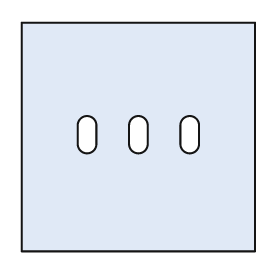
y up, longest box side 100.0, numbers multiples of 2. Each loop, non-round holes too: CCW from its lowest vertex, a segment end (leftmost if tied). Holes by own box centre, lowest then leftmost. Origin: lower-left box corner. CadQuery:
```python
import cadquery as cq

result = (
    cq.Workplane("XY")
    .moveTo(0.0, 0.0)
    .lineTo(100.0, 0.0)
    .lineTo(100.0, 98.0)
    .lineTo(0.0, 98.0)
    .close()
    .moveTo(24.0, 46.0)
    .threePointArc((28.0, 42.0), (32.0, 46.0))
    .lineTo(32.0, 54.0)
    .threePointArc((28.0, 58.0), (24.0, 54.0))
    .close()
    .moveTo(46.0, 46.0)
    .threePointArc((50.0, 42.0), (54.0, 46.0))
    .lineTo(54.0, 54.0)
    .threePointArc((50.0, 58.0), (46.0, 54.0))
    .close()
    .moveTo(68.0, 46.0)
    .threePointArc((72.0, 42.0), (76.0, 46.0))
    .lineTo(76.0, 54.0)
    .threePointArc((72.0, 58.0), (68.0, 54.0))
    .close()
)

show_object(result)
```